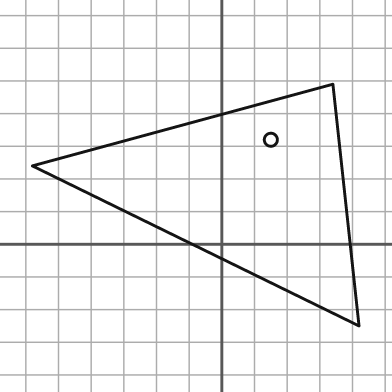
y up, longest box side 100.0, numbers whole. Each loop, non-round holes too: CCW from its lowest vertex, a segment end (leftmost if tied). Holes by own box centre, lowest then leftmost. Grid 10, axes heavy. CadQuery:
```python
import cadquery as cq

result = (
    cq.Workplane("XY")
    .moveTo(42.0, -25.0)
    .lineTo(34.0, 49.0)
    .lineTo(-58.0, 24.0)
    .close()
    .moveTo(15.0, 32.0)
    .circle(2.0)
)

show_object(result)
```